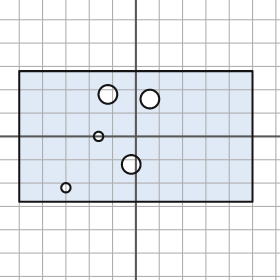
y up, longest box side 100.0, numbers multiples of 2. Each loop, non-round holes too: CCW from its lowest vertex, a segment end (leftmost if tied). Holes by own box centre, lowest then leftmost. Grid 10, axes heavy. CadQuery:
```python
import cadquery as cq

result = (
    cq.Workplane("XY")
    .moveTo(-50.0, -28.0)
    .lineTo(50.0, -28.0)
    .lineTo(50.0, 28.0)
    .lineTo(-50.0, 28.0)
    .close()
    .moveTo(-30.0, -22.0)
    .circle(2.0)
    .moveTo(-2.0, -12.0)
    .circle(4.0)
    .moveTo(-16.0, 0.0)
    .circle(2.0)
    .moveTo(6.0, 16.0)
    .circle(4.0)
    .moveTo(-12.0, 18.0)
    .circle(4.0)
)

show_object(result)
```